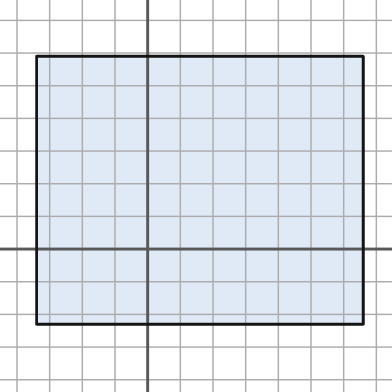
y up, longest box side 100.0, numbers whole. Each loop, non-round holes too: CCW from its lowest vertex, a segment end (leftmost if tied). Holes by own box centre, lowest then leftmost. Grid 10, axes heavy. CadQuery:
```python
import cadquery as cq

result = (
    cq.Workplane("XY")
    .moveTo(-34.0, -23.0)
    .lineTo(66.0, -23.0)
    .lineTo(66.0, 59.0)
    .lineTo(-34.0, 59.0)
    .close()
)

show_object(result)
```